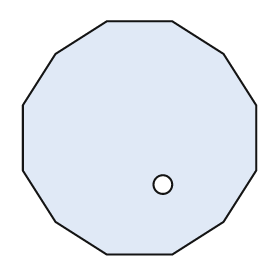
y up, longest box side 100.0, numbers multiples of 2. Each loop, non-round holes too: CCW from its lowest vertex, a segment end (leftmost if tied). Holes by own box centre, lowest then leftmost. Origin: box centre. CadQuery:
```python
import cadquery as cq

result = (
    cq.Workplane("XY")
    .moveTo(-14.0, -50.0)
    .lineTo(14.0, -50.0)
    .lineTo(36.0, -36.0)
    .lineTo(50.0, -14.0)
    .lineTo(50.0, 14.0)
    .lineTo(36.0, 36.0)
    .lineTo(14.0, 50.0)
    .lineTo(-14.0, 50.0)
    .lineTo(-36.0, 36.0)
    .lineTo(-50.0, 14.0)
    .lineTo(-50.0, -14.0)
    .lineTo(-36.0, -36.0)
    .close()
    .moveTo(10.0, -20.0)
    .circle(4.0)
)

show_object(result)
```